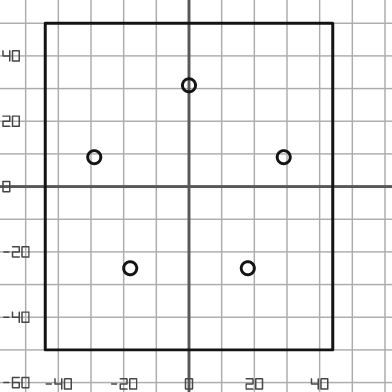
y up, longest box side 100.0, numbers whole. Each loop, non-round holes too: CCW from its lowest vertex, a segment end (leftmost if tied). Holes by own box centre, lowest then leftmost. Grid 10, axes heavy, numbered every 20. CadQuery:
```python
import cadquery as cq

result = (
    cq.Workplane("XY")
    .moveTo(-44.0, -50.0)
    .lineTo(44.0, -50.0)
    .lineTo(44.0, 50.0)
    .lineTo(-44.0, 50.0)
    .close()
    .moveTo(-18.0, -25.0)
    .circle(2.0)
    .moveTo(18.0, -25.0)
    .circle(2.0)
    .moveTo(-29.0, 9.0)
    .circle(2.0)
    .moveTo(29.0, 9.0)
    .circle(2.0)
    .moveTo(0.0, 31.0)
    .circle(2.0)
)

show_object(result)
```